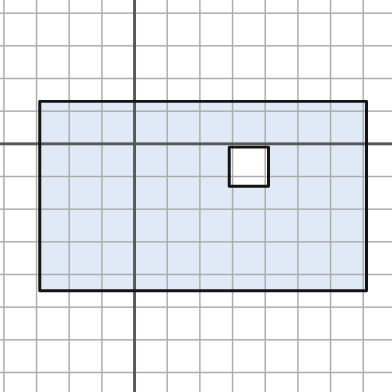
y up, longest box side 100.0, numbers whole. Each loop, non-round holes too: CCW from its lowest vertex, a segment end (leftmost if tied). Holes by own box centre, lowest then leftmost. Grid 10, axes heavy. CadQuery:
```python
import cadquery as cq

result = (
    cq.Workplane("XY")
    .moveTo(-29.0, -45.0)
    .lineTo(71.0, -45.0)
    .lineTo(71.0, 13.0)
    .lineTo(-29.0, 13.0)
    .close()
    .moveTo(29.0, -13.0)
    .lineTo(41.0, -13.0)
    .lineTo(41.0, -1.0)
    .lineTo(29.0, -1.0)
    .close()
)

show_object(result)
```